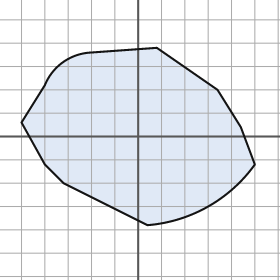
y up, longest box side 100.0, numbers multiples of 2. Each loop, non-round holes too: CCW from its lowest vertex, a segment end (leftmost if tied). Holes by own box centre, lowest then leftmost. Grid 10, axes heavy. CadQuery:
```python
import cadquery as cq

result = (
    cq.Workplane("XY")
    .moveTo(4.0, -38.0)
    .threePointArc((30.0, -30.0), (50.0, -12.0))
    .lineTo(44.0, 4.0)
    .lineTo(34.0, 20.0)
    .lineTo(8.0, 38.0)
    .lineTo(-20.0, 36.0)
    .threePointArc((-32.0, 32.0), (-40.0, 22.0))
    .lineTo(-50.0, 6.0)
    .lineTo(-40.0, -12.0)
    .lineTo(-32.0, -20.0)
    .close()
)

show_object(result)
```